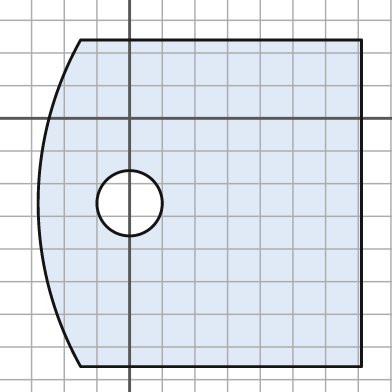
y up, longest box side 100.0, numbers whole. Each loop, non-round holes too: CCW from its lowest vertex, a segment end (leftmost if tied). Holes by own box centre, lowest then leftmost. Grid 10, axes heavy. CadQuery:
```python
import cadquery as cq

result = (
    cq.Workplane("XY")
    .moveTo(-15.0, -76.0)
    .lineTo(71.0, -76.0)
    .lineTo(71.0, 24.0)
    .lineTo(-15.0, 24.0)
    .threePointArc((-28.0, -26.0), (-15.0, -76.0))
    .close()
    .moveTo(0.0, -26.0)
    .circle(10.0)
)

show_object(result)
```